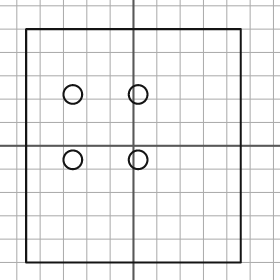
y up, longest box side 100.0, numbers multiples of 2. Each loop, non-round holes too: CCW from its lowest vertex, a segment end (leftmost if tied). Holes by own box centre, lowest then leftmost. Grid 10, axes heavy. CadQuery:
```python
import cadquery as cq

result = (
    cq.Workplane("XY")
    .moveTo(-46.0, -50.0)
    .lineTo(46.0, -50.0)
    .lineTo(46.0, 50.0)
    .lineTo(-46.0, 50.0)
    .close()
    .moveTo(-26.0, -6.0)
    .circle(4.0)
    .moveTo(2.0, -6.0)
    .circle(4.0)
    .moveTo(-26.0, 22.0)
    .circle(4.0)
    .moveTo(2.0, 22.0)
    .circle(4.0)
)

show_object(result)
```